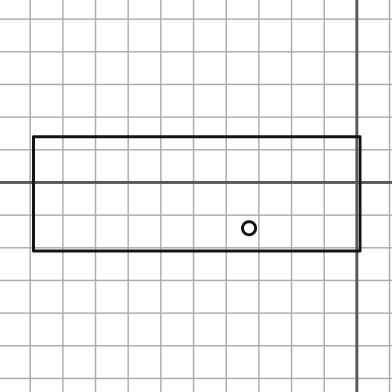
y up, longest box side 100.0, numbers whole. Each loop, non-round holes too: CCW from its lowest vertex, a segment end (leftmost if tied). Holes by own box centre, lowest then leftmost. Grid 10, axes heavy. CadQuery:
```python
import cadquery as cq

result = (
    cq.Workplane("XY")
    .moveTo(-99.0, -21.0)
    .lineTo(1.0, -21.0)
    .lineTo(1.0, 14.0)
    .lineTo(-99.0, 14.0)
    .close()
    .moveTo(-33.0, -14.0)
    .circle(2.0)
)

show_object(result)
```